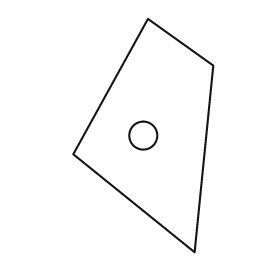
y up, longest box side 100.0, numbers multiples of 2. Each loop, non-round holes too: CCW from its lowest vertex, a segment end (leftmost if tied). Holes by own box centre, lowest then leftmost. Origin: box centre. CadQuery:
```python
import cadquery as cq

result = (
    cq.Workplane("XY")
    .moveTo(22.0, -50.0)
    .lineTo(30.0, 30.0)
    .lineTo(2.0, 50.0)
    .lineTo(-30.0, -8.0)
    .close()
    .moveTo(0.0, 0.0)
    .circle(6.0)
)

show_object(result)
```